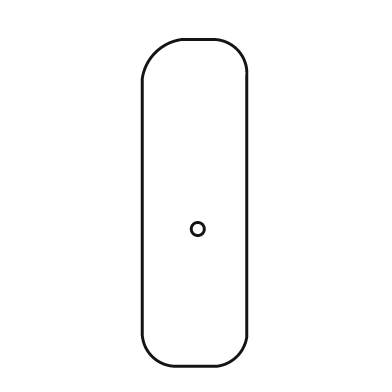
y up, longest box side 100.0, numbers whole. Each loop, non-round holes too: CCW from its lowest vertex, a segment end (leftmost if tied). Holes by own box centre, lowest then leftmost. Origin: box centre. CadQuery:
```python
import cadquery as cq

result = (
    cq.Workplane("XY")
    .moveTo(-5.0, -50.0)
    .lineTo(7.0, -50.0)
    .threePointArc((13.0, -47.0), (16.0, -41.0))
    .lineTo(16.0, 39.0)
    .threePointArc((13.0, 47.0), (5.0, 50.0))
    .lineTo(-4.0, 50.0)
    .threePointArc((-12.0, 46.0), (-16.0, 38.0))
    .lineTo(-16.0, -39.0)
    .threePointArc((-13.0, -47.0), (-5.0, -50.0))
    .close()
    .moveTo(1.0, -8.0)
    .circle(2.0)
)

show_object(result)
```